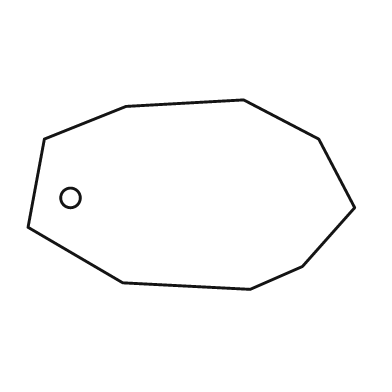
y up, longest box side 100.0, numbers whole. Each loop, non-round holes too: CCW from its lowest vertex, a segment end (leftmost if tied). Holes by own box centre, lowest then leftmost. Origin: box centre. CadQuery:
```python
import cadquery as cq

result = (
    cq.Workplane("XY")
    .moveTo(18.0, -29.0)
    .lineTo(34.0, -22.0)
    .lineTo(50.0, -4.0)
    .lineTo(39.0, 17.0)
    .lineTo(16.0, 29.0)
    .lineTo(-20.0, 27.0)
    .lineTo(-45.0, 17.0)
    .lineTo(-50.0, -10.0)
    .lineTo(-21.0, -27.0)
    .close()
    .moveTo(-37.0, -1.0)
    .circle(3.0)
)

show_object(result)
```